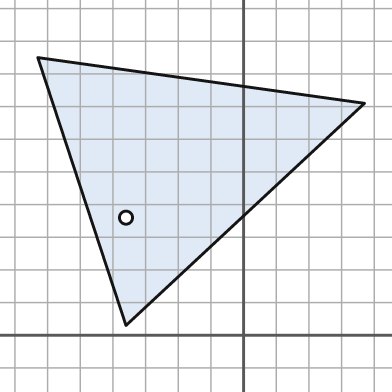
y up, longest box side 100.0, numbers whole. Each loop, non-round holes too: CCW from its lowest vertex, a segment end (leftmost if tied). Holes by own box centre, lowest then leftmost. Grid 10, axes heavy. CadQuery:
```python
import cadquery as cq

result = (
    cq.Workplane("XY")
    .moveTo(-36.0, 3.0)
    .lineTo(37.0, 71.0)
    .lineTo(-63.0, 85.0)
    .close()
    .moveTo(-36.0, 36.0)
    .circle(2.0)
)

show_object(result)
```